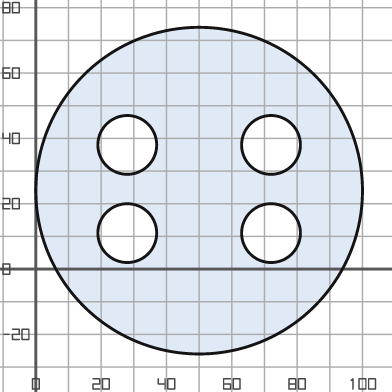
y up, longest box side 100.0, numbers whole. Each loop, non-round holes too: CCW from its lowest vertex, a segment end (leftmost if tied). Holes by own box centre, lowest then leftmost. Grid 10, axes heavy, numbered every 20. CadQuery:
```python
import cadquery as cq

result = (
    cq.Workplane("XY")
    .moveTo(50.0, 24.0)
    .circle(50.0)
    .moveTo(28.0, 11.0)
    .circle(9.0)
    .moveTo(72.0, 11.0)
    .circle(9.0)
    .moveTo(28.0, 38.0)
    .circle(9.0)
    .moveTo(72.0, 38.0)
    .circle(9.0)
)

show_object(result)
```